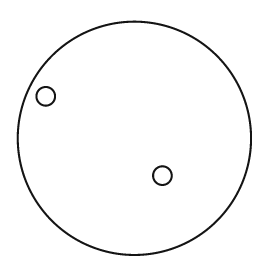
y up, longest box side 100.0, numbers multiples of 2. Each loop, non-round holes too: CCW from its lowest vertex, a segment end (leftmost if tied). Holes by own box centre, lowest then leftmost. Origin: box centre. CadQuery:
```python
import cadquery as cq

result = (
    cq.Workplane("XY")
    .moveTo(0.0, 0.0)
    .circle(50.0)
    .moveTo(12.0, -16.0)
    .circle(4.0)
    .moveTo(-38.0, 18.0)
    .circle(4.0)
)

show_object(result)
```